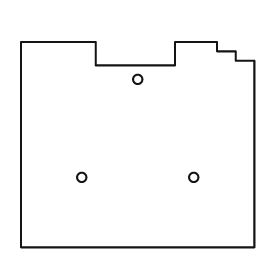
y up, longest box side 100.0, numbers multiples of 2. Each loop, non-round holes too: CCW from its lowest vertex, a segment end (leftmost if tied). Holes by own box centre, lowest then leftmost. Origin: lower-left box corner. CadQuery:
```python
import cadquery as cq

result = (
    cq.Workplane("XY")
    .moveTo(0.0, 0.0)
    .lineTo(100.0, 0.0)
    .lineTo(100.0, 80.0)
    .lineTo(92.0, 80.0)
    .lineTo(92.0, 84.0)
    .lineTo(84.0, 84.0)
    .lineTo(84.0, 88.0)
    .lineTo(66.0, 88.0)
    .lineTo(66.0, 78.0)
    .lineTo(32.0, 78.0)
    .lineTo(32.0, 88.0)
    .lineTo(0.0, 88.0)
    .close()
    .moveTo(26.0, 30.0)
    .circle(2.0)
    .moveTo(74.0, 30.0)
    .circle(2.0)
    .moveTo(50.0, 72.0)
    .circle(2.0)
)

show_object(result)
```